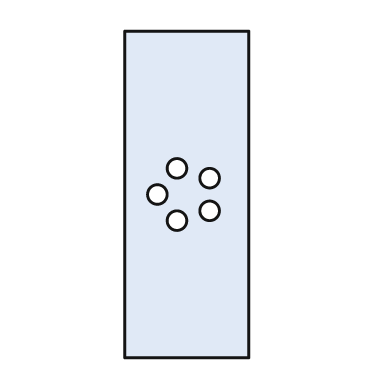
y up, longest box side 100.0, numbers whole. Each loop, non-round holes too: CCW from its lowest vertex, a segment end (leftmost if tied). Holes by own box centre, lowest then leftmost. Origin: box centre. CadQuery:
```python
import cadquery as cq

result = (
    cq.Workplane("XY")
    .moveTo(-19.0, -50.0)
    .lineTo(19.0, -50.0)
    .lineTo(19.0, 50.0)
    .lineTo(-19.0, 50.0)
    .close()
    .moveTo(-3.0, -8.0)
    .circle(3.0)
    .moveTo(7.0, -5.0)
    .circle(3.0)
    .moveTo(-9.0, 0.0)
    .circle(3.0)
    .moveTo(7.0, 5.0)
    .circle(3.0)
    .moveTo(-3.0, 8.0)
    .circle(3.0)
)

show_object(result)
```